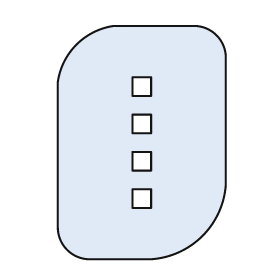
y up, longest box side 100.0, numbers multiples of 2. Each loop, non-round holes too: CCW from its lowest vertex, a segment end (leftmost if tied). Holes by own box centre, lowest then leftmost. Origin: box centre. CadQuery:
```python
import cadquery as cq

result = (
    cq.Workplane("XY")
    .moveTo(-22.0, -50.0)
    .lineTo(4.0, -50.0)
    .threePointArc((26.0, -40.0), (36.0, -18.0))
    .lineTo(36.0, 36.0)
    .threePointArc((32.0, 46.0), (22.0, 50.0))
    .lineTo(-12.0, 50.0)
    .threePointArc((-28.0, 42.0), (-36.0, 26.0))
    .lineTo(-36.0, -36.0)
    .threePointArc((-32.0, -46.0), (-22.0, -50.0))
    .close()
    .moveTo(-4.0, -28.0)
    .lineTo(4.0, -28.0)
    .lineTo(4.0, -20.0)
    .lineTo(-4.0, -20.0)
    .close()
    .moveTo(-4.0, -12.0)
    .lineTo(4.0, -12.0)
    .lineTo(4.0, -4.0)
    .lineTo(-4.0, -4.0)
    .close()
    .moveTo(-4.0, 4.0)
    .lineTo(4.0, 4.0)
    .lineTo(4.0, 12.0)
    .lineTo(-4.0, 12.0)
    .close()
    .moveTo(-4.0, 20.0)
    .lineTo(4.0, 20.0)
    .lineTo(4.0, 28.0)
    .lineTo(-4.0, 28.0)
    .close()
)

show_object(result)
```